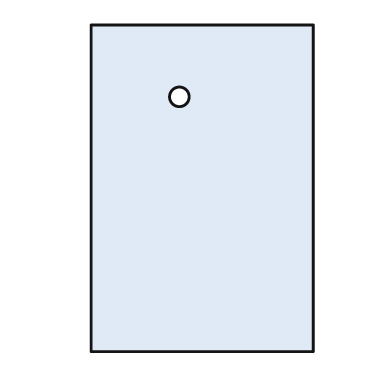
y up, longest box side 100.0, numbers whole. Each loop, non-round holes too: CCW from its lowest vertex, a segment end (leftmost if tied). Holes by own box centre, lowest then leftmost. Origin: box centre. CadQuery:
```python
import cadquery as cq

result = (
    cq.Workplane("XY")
    .moveTo(-34.0, -50.0)
    .lineTo(34.0, -50.0)
    .lineTo(34.0, 50.0)
    .lineTo(-34.0, 50.0)
    .close()
    .moveTo(-7.0, 28.0)
    .circle(3.0)
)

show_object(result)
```